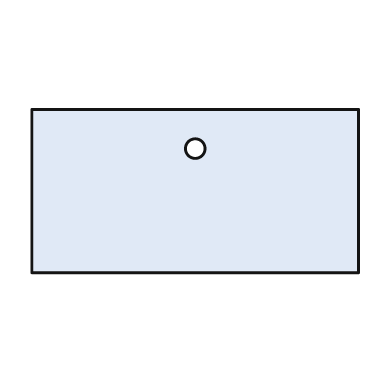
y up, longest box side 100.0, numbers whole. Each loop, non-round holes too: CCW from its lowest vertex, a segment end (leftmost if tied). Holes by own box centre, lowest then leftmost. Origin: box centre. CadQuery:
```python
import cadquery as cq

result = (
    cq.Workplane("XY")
    .moveTo(-50.0, -25.0)
    .lineTo(50.0, -25.0)
    .lineTo(50.0, 25.0)
    .lineTo(-50.0, 25.0)
    .close()
    .moveTo(0.0, 13.0)
    .circle(3.0)
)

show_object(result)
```